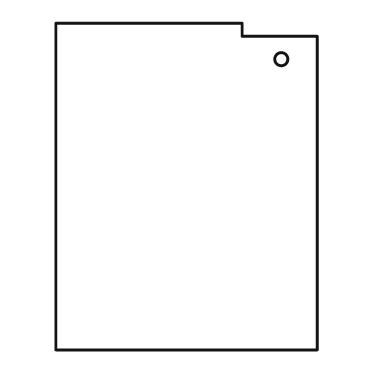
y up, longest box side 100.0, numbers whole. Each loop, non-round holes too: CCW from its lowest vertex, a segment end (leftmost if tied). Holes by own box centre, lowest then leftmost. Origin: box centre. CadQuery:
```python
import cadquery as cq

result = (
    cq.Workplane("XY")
    .moveTo(-40.0, -50.0)
    .lineTo(40.0, -50.0)
    .lineTo(40.0, 46.0)
    .lineTo(17.0, 46.0)
    .lineTo(17.0, 50.0)
    .lineTo(-40.0, 50.0)
    .close()
    .moveTo(29.0, 39.0)
    .circle(2.0)
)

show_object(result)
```